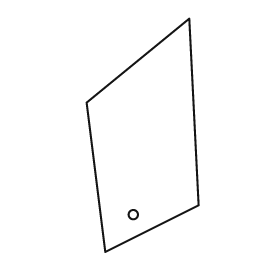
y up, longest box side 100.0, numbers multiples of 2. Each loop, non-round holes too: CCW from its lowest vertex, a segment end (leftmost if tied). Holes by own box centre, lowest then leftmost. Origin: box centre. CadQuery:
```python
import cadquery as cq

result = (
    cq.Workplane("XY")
    .moveTo(-16.0, -50.0)
    .lineTo(24.0, -30.0)
    .lineTo(20.0, 50.0)
    .lineTo(-24.0, 14.0)
    .close()
    .moveTo(-4.0, -34.0)
    .circle(2.0)
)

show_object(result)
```